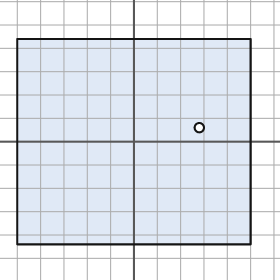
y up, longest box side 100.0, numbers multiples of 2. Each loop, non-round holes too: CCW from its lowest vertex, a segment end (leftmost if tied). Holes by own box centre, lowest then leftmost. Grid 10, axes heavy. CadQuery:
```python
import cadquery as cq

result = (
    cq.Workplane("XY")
    .moveTo(-50.0, -44.0)
    .lineTo(50.0, -44.0)
    .lineTo(50.0, 44.0)
    .lineTo(-50.0, 44.0)
    .close()
    .moveTo(28.0, 6.0)
    .circle(2.0)
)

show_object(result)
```